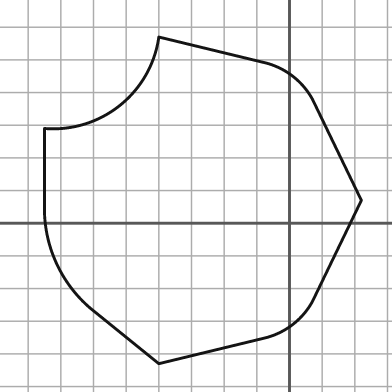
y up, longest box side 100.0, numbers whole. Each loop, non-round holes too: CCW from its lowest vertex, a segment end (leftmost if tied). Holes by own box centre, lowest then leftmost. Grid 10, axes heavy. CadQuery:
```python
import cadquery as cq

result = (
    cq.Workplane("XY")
    .moveTo(-40.0, -43.0)
    .lineTo(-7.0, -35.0)
    .threePointArc((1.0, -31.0), (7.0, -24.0))
    .lineTo(22.0, 7.0)
    .lineTo(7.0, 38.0)
    .threePointArc((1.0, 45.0), (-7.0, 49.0))
    .lineTo(-40.0, 57.0)
    .threePointArc((-52.0, 36.0), (-75.0, 29.0))
    .lineTo(-75.0, 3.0)
    .threePointArc((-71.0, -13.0), (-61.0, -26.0))
    .close()
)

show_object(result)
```